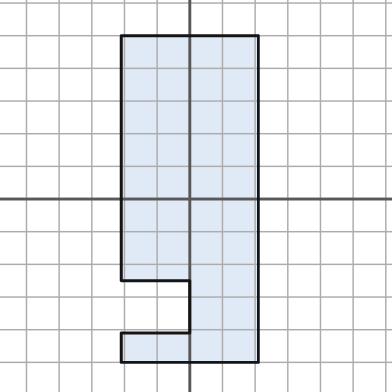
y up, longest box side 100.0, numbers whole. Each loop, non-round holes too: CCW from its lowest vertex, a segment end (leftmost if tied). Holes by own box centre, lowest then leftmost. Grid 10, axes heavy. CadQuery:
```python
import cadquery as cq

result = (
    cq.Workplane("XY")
    .moveTo(-21.0, -50.0)
    .lineTo(21.0, -50.0)
    .lineTo(21.0, 50.0)
    .lineTo(-21.0, 50.0)
    .lineTo(-21.0, -25.0)
    .lineTo(0.0, -25.0)
    .lineTo(0.0, -41.0)
    .lineTo(-21.0, -41.0)
    .close()
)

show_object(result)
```